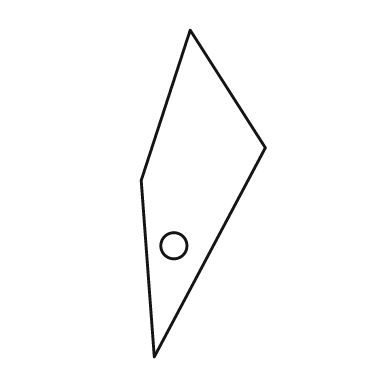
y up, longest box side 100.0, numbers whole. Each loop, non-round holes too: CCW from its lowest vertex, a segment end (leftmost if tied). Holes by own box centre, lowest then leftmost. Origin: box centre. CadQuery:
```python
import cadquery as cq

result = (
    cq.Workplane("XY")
    .moveTo(-15.0, -50.0)
    .lineTo(19.0, 14.0)
    .lineTo(-4.0, 50.0)
    .lineTo(-19.0, 4.0)
    .close()
    .moveTo(-9.0, -16.0)
    .circle(4.0)
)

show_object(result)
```